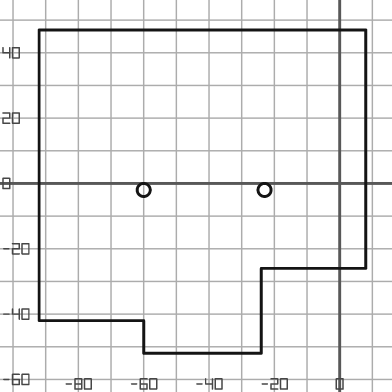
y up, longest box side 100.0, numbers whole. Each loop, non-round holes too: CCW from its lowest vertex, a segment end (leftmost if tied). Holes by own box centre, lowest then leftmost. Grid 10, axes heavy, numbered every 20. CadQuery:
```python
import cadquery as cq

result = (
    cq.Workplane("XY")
    .moveTo(-60.0, -52.0)
    .lineTo(-24.0, -52.0)
    .lineTo(-24.0, -26.0)
    .lineTo(8.0, -26.0)
    .lineTo(8.0, 47.0)
    .lineTo(-92.0, 47.0)
    .lineTo(-92.0, -42.0)
    .lineTo(-60.0, -42.0)
    .close()
    .moveTo(-60.0, -2.0)
    .circle(2.0)
    .moveTo(-23.0, -2.0)
    .circle(2.0)
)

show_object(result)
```